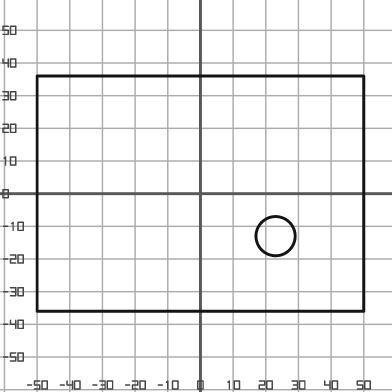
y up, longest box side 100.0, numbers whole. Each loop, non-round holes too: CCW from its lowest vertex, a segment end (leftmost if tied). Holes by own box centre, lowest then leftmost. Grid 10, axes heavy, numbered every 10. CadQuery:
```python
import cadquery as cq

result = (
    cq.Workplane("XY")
    .moveTo(-50.0, -36.0)
    .lineTo(50.0, -36.0)
    .lineTo(50.0, 36.0)
    .lineTo(-50.0, 36.0)
    .close()
    .moveTo(23.0, -13.0)
    .circle(6.0)
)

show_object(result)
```